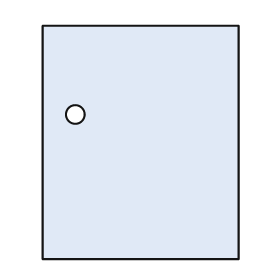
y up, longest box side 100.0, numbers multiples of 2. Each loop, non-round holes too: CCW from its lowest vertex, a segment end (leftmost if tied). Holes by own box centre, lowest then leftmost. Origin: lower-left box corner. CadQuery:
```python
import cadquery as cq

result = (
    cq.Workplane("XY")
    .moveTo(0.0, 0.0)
    .lineTo(84.0, 0.0)
    .lineTo(84.0, 100.0)
    .lineTo(0.0, 100.0)
    .close()
    .moveTo(14.0, 62.0)
    .circle(4.0)
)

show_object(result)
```